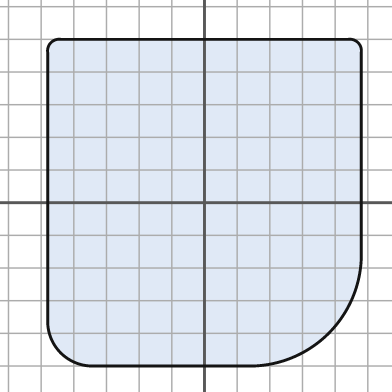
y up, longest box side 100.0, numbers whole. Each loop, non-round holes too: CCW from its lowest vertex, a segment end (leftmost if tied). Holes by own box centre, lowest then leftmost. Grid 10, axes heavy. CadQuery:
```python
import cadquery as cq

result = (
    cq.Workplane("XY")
    .moveTo(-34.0, -50.0)
    .lineTo(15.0, -50.0)
    .threePointArc((38.0, -40.0), (48.0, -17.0))
    .lineTo(48.0, 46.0)
    .threePointArc((47.0, 49.0), (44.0, 50.0))
    .lineTo(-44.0, 50.0)
    .threePointArc((-47.0, 49.0), (-48.0, 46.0))
    .lineTo(-48.0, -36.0)
    .threePointArc((-44.0, -46.0), (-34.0, -50.0))
    .close()
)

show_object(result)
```